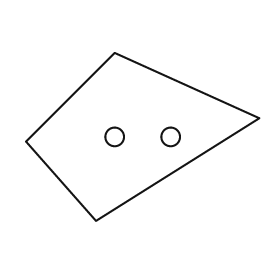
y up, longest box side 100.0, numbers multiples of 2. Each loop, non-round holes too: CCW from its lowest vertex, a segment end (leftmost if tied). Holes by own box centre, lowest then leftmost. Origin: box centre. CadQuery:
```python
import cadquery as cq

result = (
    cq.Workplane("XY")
    .moveTo(-20.0, -36.0)
    .lineTo(50.0, 8.0)
    .lineTo(-12.0, 36.0)
    .lineTo(-50.0, -2.0)
    .close()
    .moveTo(-12.0, 0.0)
    .circle(4.0)
    .moveTo(12.0, 0.0)
    .circle(4.0)
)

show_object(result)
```